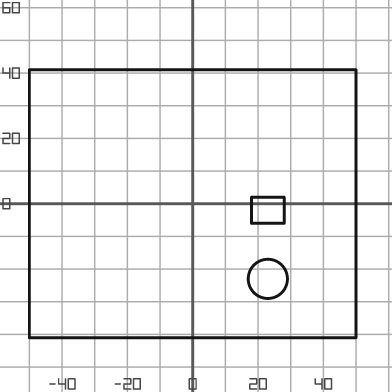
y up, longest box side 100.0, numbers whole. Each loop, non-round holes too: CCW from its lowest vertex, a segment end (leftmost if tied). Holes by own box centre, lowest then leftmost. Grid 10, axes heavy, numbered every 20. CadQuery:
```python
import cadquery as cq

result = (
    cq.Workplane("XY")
    .moveTo(-50.0, -41.0)
    .lineTo(50.0, -41.0)
    .lineTo(50.0, 41.0)
    .lineTo(-50.0, 41.0)
    .close()
    .moveTo(23.0, -23.0)
    .circle(6.0)
    .moveTo(18.0, -6.0)
    .lineTo(28.0, -6.0)
    .lineTo(28.0, 2.0)
    .lineTo(18.0, 2.0)
    .close()
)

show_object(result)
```